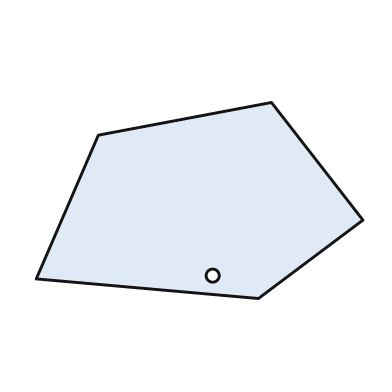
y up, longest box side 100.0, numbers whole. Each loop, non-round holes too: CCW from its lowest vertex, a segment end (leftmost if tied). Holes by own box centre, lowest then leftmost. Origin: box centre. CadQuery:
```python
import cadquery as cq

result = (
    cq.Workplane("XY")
    .moveTo(18.0, -30.0)
    .lineTo(50.0, -6.0)
    .lineTo(22.0, 30.0)
    .lineTo(-31.0, 20.0)
    .lineTo(-50.0, -24.0)
    .close()
    .moveTo(4.0, -23.0)
    .circle(2.0)
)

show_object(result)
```